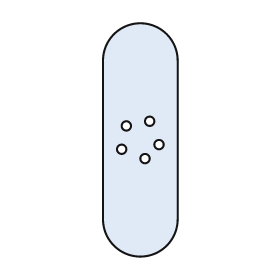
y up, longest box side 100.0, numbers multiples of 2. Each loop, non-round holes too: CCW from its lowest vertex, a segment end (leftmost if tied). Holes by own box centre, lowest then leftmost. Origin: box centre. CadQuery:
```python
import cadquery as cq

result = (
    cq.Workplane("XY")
    .moveTo(-16.0, -34.0)
    .threePointArc((0.0, -50.0), (16.0, -34.0))
    .lineTo(16.0, 34.0)
    .threePointArc((0.0, 50.0), (-16.0, 34.0))
    .close()
    .moveTo(2.0, -8.0)
    .circle(2.0)
    .moveTo(-8.0, -4.0)
    .circle(2.0)
    .moveTo(8.0, -2.0)
    .circle(2.0)
    .moveTo(-6.0, 6.0)
    .circle(2.0)
    .moveTo(4.0, 8.0)
    .circle(2.0)
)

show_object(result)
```